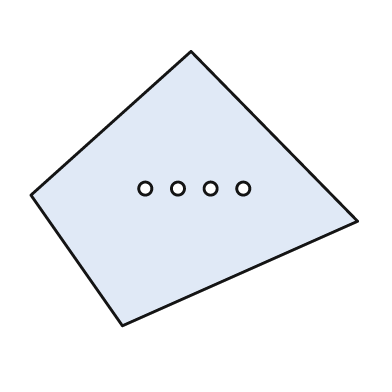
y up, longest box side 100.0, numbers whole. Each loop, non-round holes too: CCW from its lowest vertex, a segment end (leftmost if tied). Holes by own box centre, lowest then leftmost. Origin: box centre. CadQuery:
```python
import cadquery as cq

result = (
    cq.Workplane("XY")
    .moveTo(-22.0, -42.0)
    .lineTo(50.0, -10.0)
    .lineTo(-1.0, 42.0)
    .lineTo(-50.0, -2.0)
    .close()
    .moveTo(-15.0, 0.0)
    .circle(2.0)
    .moveTo(-5.0, 0.0)
    .circle(2.0)
    .moveTo(5.0, 0.0)
    .circle(2.0)
    .moveTo(15.0, 0.0)
    .circle(2.0)
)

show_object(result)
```